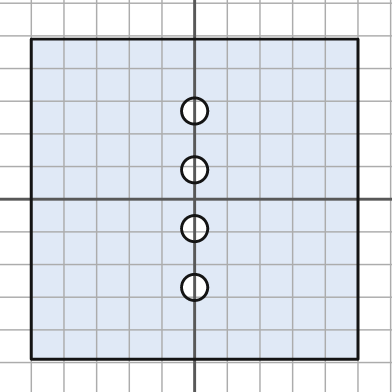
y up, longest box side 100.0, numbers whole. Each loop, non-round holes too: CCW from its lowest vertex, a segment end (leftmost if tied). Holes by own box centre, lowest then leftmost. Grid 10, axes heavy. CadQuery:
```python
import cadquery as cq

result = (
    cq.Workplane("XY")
    .moveTo(-50.0, -49.0)
    .lineTo(50.0, -49.0)
    .lineTo(50.0, 49.0)
    .lineTo(-50.0, 49.0)
    .close()
    .moveTo(0.0, -27.0)
    .circle(4.0)
    .moveTo(0.0, -9.0)
    .circle(4.0)
    .moveTo(0.0, 9.0)
    .circle(4.0)
    .moveTo(0.0, 27.0)
    .circle(4.0)
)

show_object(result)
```